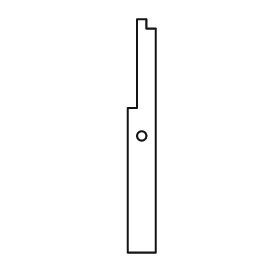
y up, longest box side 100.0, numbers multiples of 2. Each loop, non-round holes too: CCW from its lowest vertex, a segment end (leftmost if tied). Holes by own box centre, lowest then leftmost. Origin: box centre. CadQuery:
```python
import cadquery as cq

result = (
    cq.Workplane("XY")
    .moveTo(-6.0, -50.0)
    .lineTo(6.0, -50.0)
    .lineTo(6.0, 46.0)
    .lineTo(2.0, 46.0)
    .lineTo(2.0, 50.0)
    .lineTo(-2.0, 50.0)
    .lineTo(-2.0, 12.0)
    .lineTo(-6.0, 12.0)
    .close()
    .moveTo(0.0, 0.0)
    .circle(2.0)
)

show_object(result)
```